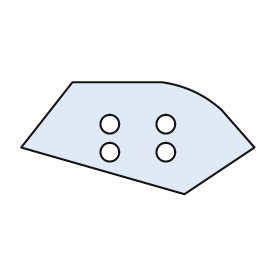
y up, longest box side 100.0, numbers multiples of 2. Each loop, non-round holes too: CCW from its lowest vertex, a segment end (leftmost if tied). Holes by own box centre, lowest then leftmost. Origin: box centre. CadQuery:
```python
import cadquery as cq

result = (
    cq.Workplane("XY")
    .moveTo(20.0, -24.0)
    .lineTo(50.0, -4.0)
    .lineTo(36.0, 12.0)
    .threePointArc((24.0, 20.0), (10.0, 24.0))
    .lineTo(-28.0, 24.0)
    .lineTo(-50.0, -4.0)
    .close()
    .moveTo(-12.0, -6.0)
    .circle(4.0)
    .moveTo(12.0, -6.0)
    .circle(4.0)
    .moveTo(-12.0, 6.0)
    .circle(4.0)
    .moveTo(12.0, 6.0)
    .circle(4.0)
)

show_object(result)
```